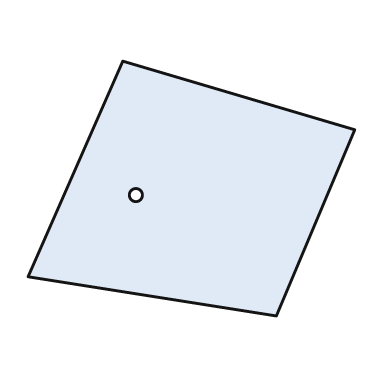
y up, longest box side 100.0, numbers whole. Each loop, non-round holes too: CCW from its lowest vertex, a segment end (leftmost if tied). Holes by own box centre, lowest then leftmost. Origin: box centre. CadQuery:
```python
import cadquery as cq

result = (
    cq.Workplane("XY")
    .moveTo(26.0, -39.0)
    .lineTo(50.0, 18.0)
    .lineTo(-21.0, 39.0)
    .lineTo(-50.0, -27.0)
    .close()
    .moveTo(-17.0, -2.0)
    .circle(2.0)
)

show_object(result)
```